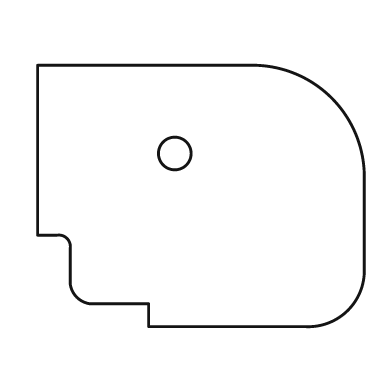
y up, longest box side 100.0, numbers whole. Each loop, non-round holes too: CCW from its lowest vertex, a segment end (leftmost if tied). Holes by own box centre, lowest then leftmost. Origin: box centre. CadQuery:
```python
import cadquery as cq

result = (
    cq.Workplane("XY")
    .moveTo(-16.0, -40.0)
    .lineTo(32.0, -40.0)
    .threePointArc((45.0, -35.0), (50.0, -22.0))
    .lineTo(50.0, 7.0)
    .threePointArc((40.0, 30.0), (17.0, 40.0))
    .lineTo(-50.0, 40.0)
    .lineTo(-50.0, -12.0)
    .lineTo(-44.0, -12.0)
    .threePointArc((-41.0, -13.0), (-40.0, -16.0))
    .lineTo(-40.0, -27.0)
    .threePointArc((-38.0, -31.0), (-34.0, -33.0))
    .lineTo(-16.0, -33.0)
    .close()
    .moveTo(-8.0, 13.0)
    .circle(5.0)
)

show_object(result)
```